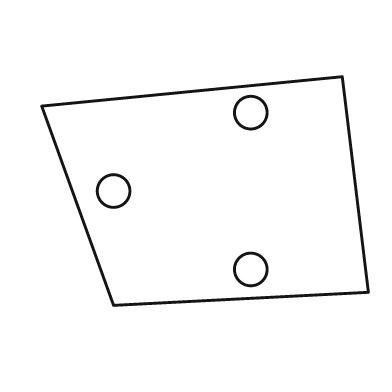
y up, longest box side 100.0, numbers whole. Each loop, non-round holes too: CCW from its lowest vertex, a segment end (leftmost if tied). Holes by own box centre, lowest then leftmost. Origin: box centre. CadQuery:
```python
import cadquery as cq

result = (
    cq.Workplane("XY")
    .moveTo(-28.0, -35.0)
    .lineTo(50.0, -31.0)
    .lineTo(42.0, 35.0)
    .lineTo(-50.0, 26.0)
    .close()
    .moveTo(14.0, -24.0)
    .circle(5.0)
    .moveTo(-28.0, 0.0)
    .circle(5.0)
    .moveTo(14.0, 24.0)
    .circle(5.0)
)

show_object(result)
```